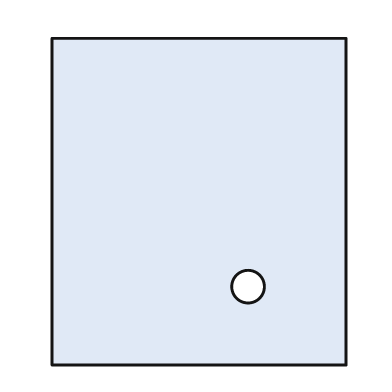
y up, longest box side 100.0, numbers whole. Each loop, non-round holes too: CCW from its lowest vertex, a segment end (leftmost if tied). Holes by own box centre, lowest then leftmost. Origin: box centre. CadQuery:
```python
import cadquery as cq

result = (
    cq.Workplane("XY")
    .moveTo(-45.0, -50.0)
    .lineTo(45.0, -50.0)
    .lineTo(45.0, 50.0)
    .lineTo(-45.0, 50.0)
    .close()
    .moveTo(15.0, -26.0)
    .circle(5.0)
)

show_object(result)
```